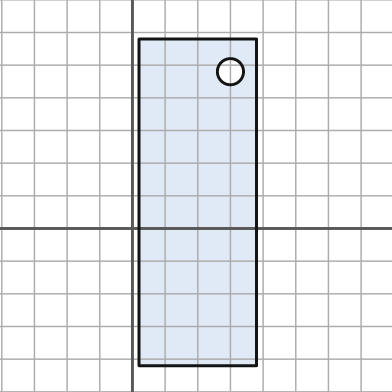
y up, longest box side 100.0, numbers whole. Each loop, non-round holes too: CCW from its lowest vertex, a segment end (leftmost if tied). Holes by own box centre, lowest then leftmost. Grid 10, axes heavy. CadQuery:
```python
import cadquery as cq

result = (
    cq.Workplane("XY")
    .moveTo(2.0, -42.0)
    .lineTo(38.0, -42.0)
    .lineTo(38.0, 58.0)
    .lineTo(2.0, 58.0)
    .close()
    .moveTo(30.0, 48.0)
    .circle(4.0)
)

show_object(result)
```